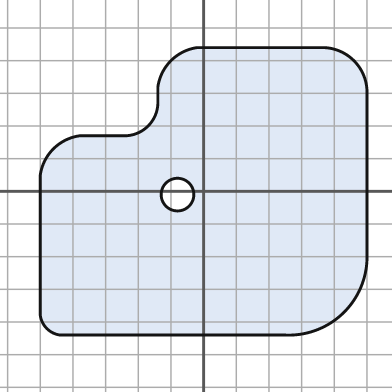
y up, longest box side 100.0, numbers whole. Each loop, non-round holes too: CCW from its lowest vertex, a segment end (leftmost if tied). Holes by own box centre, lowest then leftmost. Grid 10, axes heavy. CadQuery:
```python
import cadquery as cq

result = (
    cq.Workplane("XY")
    .moveTo(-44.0, -44.0)
    .lineTo(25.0, -44.0)
    .threePointArc((43.0, -37.0), (50.0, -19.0))
    .lineTo(50.0, 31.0)
    .threePointArc((46.0, 40.0), (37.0, 44.0))
    .lineTo(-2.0, 44.0)
    .threePointArc((-10.0, 40.0), (-14.0, 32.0))
    .lineTo(-14.0, 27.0)
    .threePointArc((-17.0, 20.0), (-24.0, 17.0))
    .lineTo(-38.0, 17.0)
    .threePointArc((-46.0, 13.0), (-50.0, 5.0))
    .lineTo(-50.0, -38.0)
    .threePointArc((-48.0, -42.0), (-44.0, -44.0))
    .close()
    .moveTo(-8.0, -1.0)
    .circle(5.0)
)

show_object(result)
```